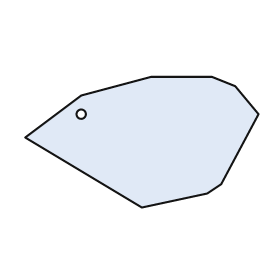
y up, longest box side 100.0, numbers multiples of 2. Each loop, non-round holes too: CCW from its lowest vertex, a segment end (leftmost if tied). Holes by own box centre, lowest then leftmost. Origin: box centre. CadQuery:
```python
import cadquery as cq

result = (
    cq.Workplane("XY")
    .moveTo(0.0, -28.0)
    .lineTo(28.0, -22.0)
    .lineTo(34.0, -18.0)
    .lineTo(50.0, 12.0)
    .lineTo(40.0, 24.0)
    .lineTo(30.0, 28.0)
    .lineTo(4.0, 28.0)
    .lineTo(-26.0, 20.0)
    .lineTo(-50.0, 2.0)
    .close()
    .moveTo(-26.0, 12.0)
    .circle(2.0)
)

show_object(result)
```